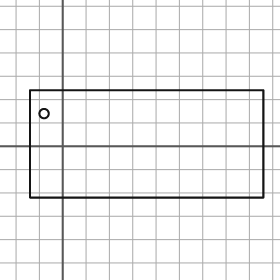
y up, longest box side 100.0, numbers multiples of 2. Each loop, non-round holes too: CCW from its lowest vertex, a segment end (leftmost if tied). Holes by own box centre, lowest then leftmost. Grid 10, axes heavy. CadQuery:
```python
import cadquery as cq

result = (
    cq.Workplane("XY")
    .moveTo(-14.0, -22.0)
    .lineTo(86.0, -22.0)
    .lineTo(86.0, 24.0)
    .lineTo(-14.0, 24.0)
    .close()
    .moveTo(-8.0, 14.0)
    .circle(2.0)
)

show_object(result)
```